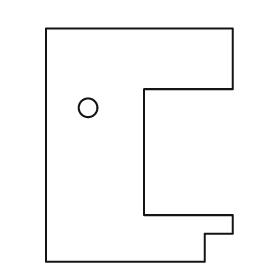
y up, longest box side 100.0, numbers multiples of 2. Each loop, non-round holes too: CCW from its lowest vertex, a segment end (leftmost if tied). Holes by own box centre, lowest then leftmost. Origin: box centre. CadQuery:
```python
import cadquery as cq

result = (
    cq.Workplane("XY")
    .moveTo(-40.0, -50.0)
    .lineTo(28.0, -50.0)
    .lineTo(28.0, -38.0)
    .lineTo(40.0, -38.0)
    .lineTo(40.0, -30.0)
    .lineTo(2.0, -30.0)
    .lineTo(2.0, 24.0)
    .lineTo(40.0, 24.0)
    .lineTo(40.0, 50.0)
    .lineTo(-40.0, 50.0)
    .close()
    .moveTo(-22.0, 16.0)
    .circle(4.0)
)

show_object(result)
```